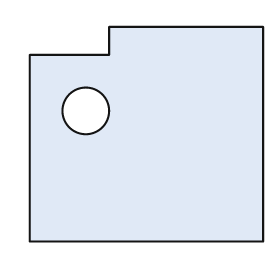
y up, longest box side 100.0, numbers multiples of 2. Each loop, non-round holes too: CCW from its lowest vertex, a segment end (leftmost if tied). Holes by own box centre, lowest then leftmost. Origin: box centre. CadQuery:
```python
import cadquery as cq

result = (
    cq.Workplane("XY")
    .moveTo(-50.0, -46.0)
    .lineTo(50.0, -46.0)
    .lineTo(50.0, 46.0)
    .lineTo(-16.0, 46.0)
    .lineTo(-16.0, 34.0)
    .lineTo(-50.0, 34.0)
    .close()
    .moveTo(-26.0, 10.0)
    .circle(10.0)
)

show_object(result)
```